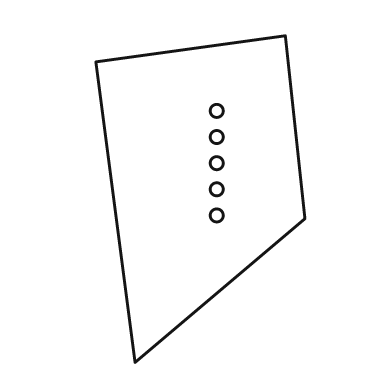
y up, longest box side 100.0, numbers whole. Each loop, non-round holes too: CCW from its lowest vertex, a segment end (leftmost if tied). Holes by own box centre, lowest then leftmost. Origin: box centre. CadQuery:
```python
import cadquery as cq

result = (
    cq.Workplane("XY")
    .moveTo(-20.0, -50.0)
    .lineTo(32.0, -6.0)
    .lineTo(26.0, 50.0)
    .lineTo(-32.0, 42.0)
    .close()
    .moveTo(5.0, -5.0)
    .circle(2.0)
    .moveTo(5.0, 3.0)
    .circle(2.0)
    .moveTo(5.0, 11.0)
    .circle(2.0)
    .moveTo(5.0, 19.0)
    .circle(2.0)
    .moveTo(5.0, 27.0)
    .circle(2.0)
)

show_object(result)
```